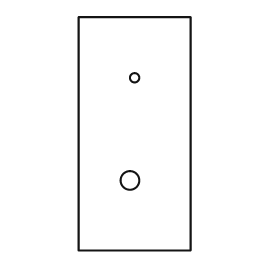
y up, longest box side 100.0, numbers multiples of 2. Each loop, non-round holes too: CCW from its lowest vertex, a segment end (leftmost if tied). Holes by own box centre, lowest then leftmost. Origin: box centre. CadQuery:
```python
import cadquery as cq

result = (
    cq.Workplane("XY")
    .moveTo(-24.0, -50.0)
    .lineTo(24.0, -50.0)
    .lineTo(24.0, 50.0)
    .lineTo(-24.0, 50.0)
    .close()
    .moveTo(-2.0, -20.0)
    .circle(4.0)
    .moveTo(0.0, 24.0)
    .circle(2.0)
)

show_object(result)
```